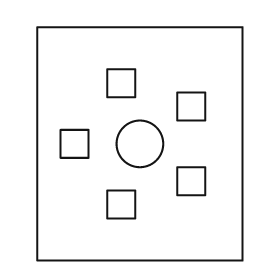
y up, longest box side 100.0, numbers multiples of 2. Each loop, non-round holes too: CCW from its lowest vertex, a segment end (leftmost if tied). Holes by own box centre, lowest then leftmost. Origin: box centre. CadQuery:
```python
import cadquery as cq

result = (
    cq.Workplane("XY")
    .moveTo(-44.0, -50.0)
    .lineTo(44.0, -50.0)
    .lineTo(44.0, 50.0)
    .lineTo(-44.0, 50.0)
    .close()
    .moveTo(-14.0, -32.0)
    .lineTo(-2.0, -32.0)
    .lineTo(-2.0, -20.0)
    .lineTo(-14.0, -20.0)
    .close()
    .moveTo(16.0, -22.0)
    .lineTo(28.0, -22.0)
    .lineTo(28.0, -10.0)
    .lineTo(16.0, -10.0)
    .close()
    .moveTo(-34.0, -6.0)
    .lineTo(-22.0, -6.0)
    .lineTo(-22.0, 6.0)
    .lineTo(-34.0, 6.0)
    .close()
    .moveTo(0.0, 0.0)
    .circle(10.0)
    .moveTo(16.0, 10.0)
    .lineTo(28.0, 10.0)
    .lineTo(28.0, 22.0)
    .lineTo(16.0, 22.0)
    .close()
    .moveTo(-14.0, 20.0)
    .lineTo(-2.0, 20.0)
    .lineTo(-2.0, 32.0)
    .lineTo(-14.0, 32.0)
    .close()
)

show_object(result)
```